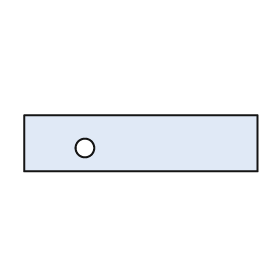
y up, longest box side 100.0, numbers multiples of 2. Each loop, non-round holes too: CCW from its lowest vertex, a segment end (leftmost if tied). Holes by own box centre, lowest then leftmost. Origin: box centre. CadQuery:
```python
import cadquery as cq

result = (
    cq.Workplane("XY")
    .moveTo(-50.0, -12.0)
    .lineTo(50.0, -12.0)
    .lineTo(50.0, 12.0)
    .lineTo(-50.0, 12.0)
    .close()
    .moveTo(-24.0, -2.0)
    .circle(4.0)
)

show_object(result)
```